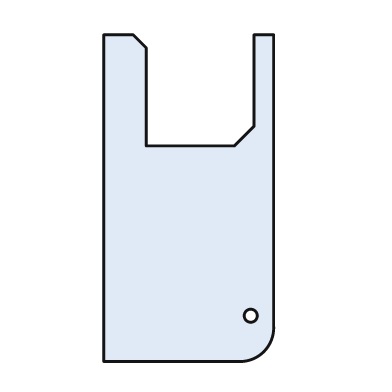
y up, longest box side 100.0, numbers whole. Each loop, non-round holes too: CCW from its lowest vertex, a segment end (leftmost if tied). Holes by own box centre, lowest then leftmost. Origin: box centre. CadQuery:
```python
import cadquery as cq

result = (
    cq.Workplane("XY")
    .moveTo(-26.0, -50.0)
    .lineTo(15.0, -50.0)
    .threePointArc((23.0, -47.0), (26.0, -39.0))
    .lineTo(26.0, 50.0)
    .lineTo(20.0, 50.0)
    .lineTo(20.0, 22.0)
    .lineTo(14.0, 16.0)
    .lineTo(-13.0, 16.0)
    .lineTo(-13.0, 46.0)
    .lineTo(-17.0, 50.0)
    .lineTo(-26.0, 50.0)
    .close()
    .moveTo(19.0, -36.0)
    .circle(2.0)
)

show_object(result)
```